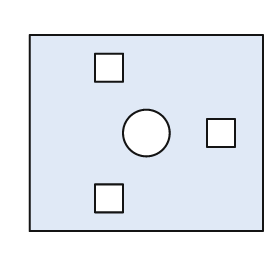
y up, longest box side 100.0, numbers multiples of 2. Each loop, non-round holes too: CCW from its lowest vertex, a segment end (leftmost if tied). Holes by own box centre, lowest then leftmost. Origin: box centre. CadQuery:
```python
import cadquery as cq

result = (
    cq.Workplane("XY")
    .moveTo(-50.0, -42.0)
    .lineTo(50.0, -42.0)
    .lineTo(50.0, 42.0)
    .lineTo(-50.0, 42.0)
    .close()
    .moveTo(-22.0, -34.0)
    .lineTo(-10.0, -34.0)
    .lineTo(-10.0, -22.0)
    .lineTo(-22.0, -22.0)
    .close()
    .moveTo(0.0, 0.0)
    .circle(10.0)
    .moveTo(26.0, -6.0)
    .lineTo(38.0, -6.0)
    .lineTo(38.0, 6.0)
    .lineTo(26.0, 6.0)
    .close()
    .moveTo(-22.0, 22.0)
    .lineTo(-10.0, 22.0)
    .lineTo(-10.0, 34.0)
    .lineTo(-22.0, 34.0)
    .close()
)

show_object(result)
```